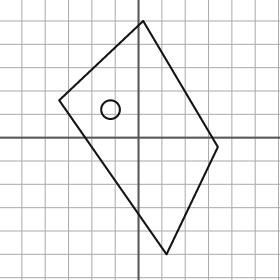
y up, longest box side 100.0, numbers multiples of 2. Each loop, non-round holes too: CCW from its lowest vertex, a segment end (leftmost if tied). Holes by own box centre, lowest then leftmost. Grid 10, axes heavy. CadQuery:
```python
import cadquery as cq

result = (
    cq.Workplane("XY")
    .moveTo(12.0, -50.0)
    .lineTo(34.0, -4.0)
    .lineTo(2.0, 50.0)
    .lineTo(-34.0, 16.0)
    .close()
    .moveTo(-12.0, 12.0)
    .circle(4.0)
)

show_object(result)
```